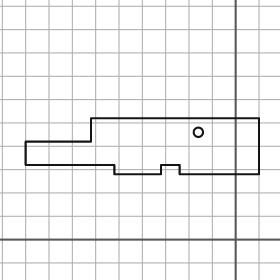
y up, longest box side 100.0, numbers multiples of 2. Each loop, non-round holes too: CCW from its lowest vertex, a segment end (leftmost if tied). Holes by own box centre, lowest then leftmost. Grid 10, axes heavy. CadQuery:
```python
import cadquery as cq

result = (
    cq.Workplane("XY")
    .moveTo(-52.0, 28.0)
    .lineTo(-32.0, 28.0)
    .lineTo(-32.0, 32.0)
    .lineTo(-24.0, 32.0)
    .lineTo(-24.0, 28.0)
    .lineTo(10.0, 28.0)
    .lineTo(10.0, 52.0)
    .lineTo(-62.0, 52.0)
    .lineTo(-62.0, 42.0)
    .lineTo(-90.0, 42.0)
    .lineTo(-90.0, 32.0)
    .lineTo(-52.0, 32.0)
    .close()
    .moveTo(-16.0, 46.0)
    .circle(2.0)
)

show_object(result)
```